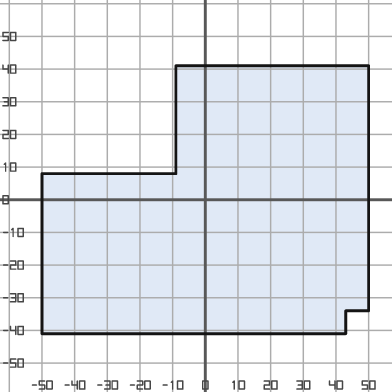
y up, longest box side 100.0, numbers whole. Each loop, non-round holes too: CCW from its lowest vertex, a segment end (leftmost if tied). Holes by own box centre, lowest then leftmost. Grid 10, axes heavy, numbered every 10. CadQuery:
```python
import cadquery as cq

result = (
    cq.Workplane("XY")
    .moveTo(-50.0, -41.0)
    .lineTo(43.0, -41.0)
    .lineTo(43.0, -34.0)
    .lineTo(50.0, -34.0)
    .lineTo(50.0, 41.0)
    .lineTo(-9.0, 41.0)
    .lineTo(-9.0, 8.0)
    .lineTo(-50.0, 8.0)
    .close()
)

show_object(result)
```